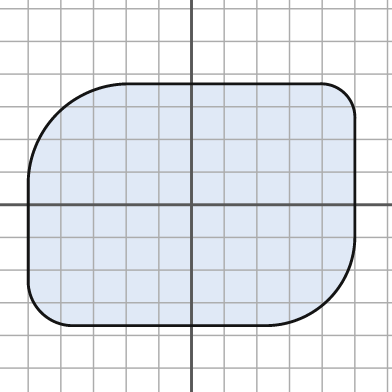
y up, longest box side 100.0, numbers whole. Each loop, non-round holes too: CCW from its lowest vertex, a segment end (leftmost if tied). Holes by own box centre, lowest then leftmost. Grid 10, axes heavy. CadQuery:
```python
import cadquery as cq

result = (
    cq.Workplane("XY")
    .moveTo(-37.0, -37.0)
    .lineTo(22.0, -37.0)
    .threePointArc((42.0, -29.0), (50.0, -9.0))
    .lineTo(50.0, 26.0)
    .threePointArc((47.0, 34.0), (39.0, 37.0))
    .lineTo(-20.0, 37.0)
    .threePointArc((-41.0, 28.0), (-50.0, 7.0))
    .lineTo(-50.0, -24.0)
    .threePointArc((-46.0, -33.0), (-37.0, -37.0))
    .close()
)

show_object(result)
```